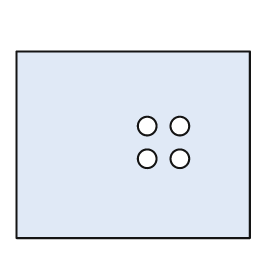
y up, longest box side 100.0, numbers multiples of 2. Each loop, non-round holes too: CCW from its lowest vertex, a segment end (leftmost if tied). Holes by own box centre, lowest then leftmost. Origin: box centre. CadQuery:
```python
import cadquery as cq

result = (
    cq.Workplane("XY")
    .moveTo(-50.0, -40.0)
    .lineTo(50.0, -40.0)
    .lineTo(50.0, 40.0)
    .lineTo(-50.0, 40.0)
    .close()
    .moveTo(6.0, -6.0)
    .circle(4.0)
    .moveTo(20.0, -6.0)
    .circle(4.0)
    .moveTo(6.0, 8.0)
    .circle(4.0)
    .moveTo(20.0, 8.0)
    .circle(4.0)
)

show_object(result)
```